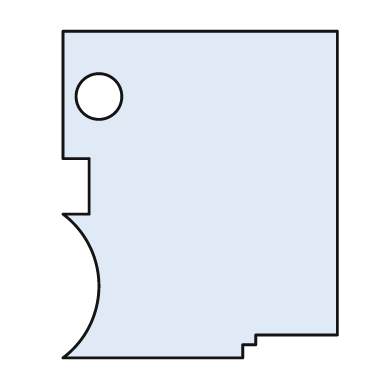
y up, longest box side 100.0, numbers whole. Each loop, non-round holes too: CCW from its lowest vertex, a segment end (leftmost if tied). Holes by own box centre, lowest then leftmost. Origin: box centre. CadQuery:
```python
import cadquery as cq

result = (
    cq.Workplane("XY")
    .moveTo(-42.0, -50.0)
    .lineTo(13.0, -50.0)
    .lineTo(13.0, -46.0)
    .lineTo(17.0, -46.0)
    .lineTo(17.0, -43.0)
    .lineTo(42.0, -43.0)
    .lineTo(42.0, 50.0)
    .lineTo(-42.0, 50.0)
    .lineTo(-42.0, 11.0)
    .lineTo(-34.0, 11.0)
    .lineTo(-34.0, -6.0)
    .lineTo(-42.0, -6.0)
    .threePointArc((-31.0, -28.0), (-42.0, -50.0))
    .close()
    .moveTo(-31.0, 30.0)
    .circle(7.0)
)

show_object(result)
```